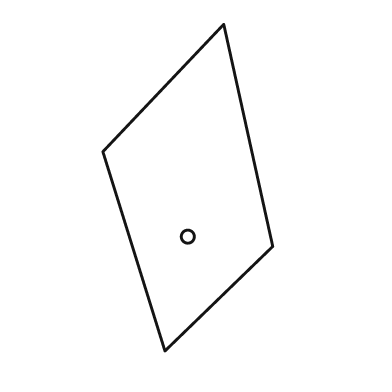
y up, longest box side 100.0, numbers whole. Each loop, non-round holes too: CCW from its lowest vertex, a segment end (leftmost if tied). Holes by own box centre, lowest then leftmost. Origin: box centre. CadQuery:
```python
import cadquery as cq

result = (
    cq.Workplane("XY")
    .moveTo(-7.0, -50.0)
    .lineTo(26.0, -18.0)
    .lineTo(11.0, 50.0)
    .lineTo(-26.0, 11.0)
    .close()
    .moveTo(0.0, -15.0)
    .circle(2.0)
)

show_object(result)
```